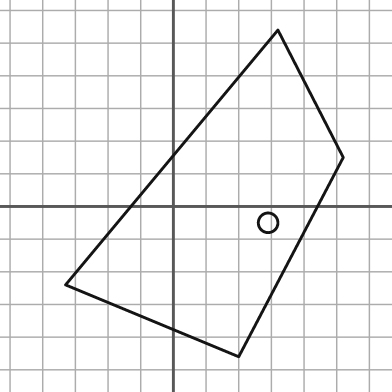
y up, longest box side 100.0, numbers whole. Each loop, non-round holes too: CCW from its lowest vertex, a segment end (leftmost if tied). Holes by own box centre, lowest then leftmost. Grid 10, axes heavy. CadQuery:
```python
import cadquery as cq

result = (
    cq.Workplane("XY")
    .moveTo(20.0, -46.0)
    .lineTo(52.0, 15.0)
    .lineTo(32.0, 54.0)
    .lineTo(-33.0, -24.0)
    .close()
    .moveTo(29.0, -5.0)
    .circle(3.0)
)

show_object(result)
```